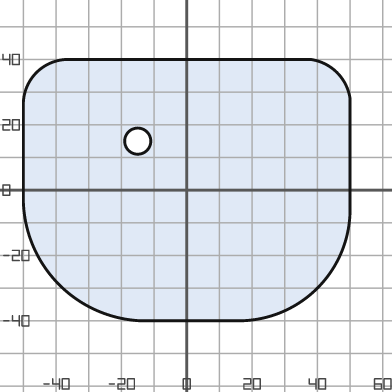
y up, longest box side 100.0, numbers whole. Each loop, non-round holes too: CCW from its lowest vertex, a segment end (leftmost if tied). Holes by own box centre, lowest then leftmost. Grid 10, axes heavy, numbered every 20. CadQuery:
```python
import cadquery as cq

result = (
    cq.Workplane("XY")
    .moveTo(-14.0, -40.0)
    .lineTo(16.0, -40.0)
    .threePointArc((40.0, -30.0), (50.0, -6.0))
    .lineTo(50.0, 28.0)
    .threePointArc((46.0, 36.0), (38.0, 40.0))
    .lineTo(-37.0, 40.0)
    .threePointArc((-46.0, 36.0), (-50.0, 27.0))
    .lineTo(-50.0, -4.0)
    .threePointArc((-39.0, -29.0), (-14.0, -40.0))
    .close()
    .moveTo(-15.0, 15.0)
    .circle(4.0)
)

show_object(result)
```